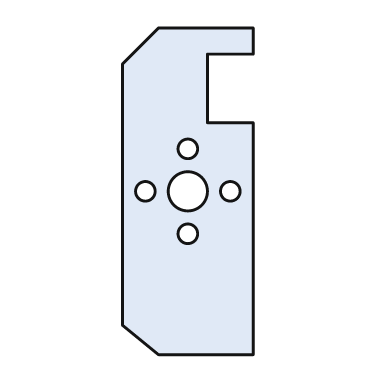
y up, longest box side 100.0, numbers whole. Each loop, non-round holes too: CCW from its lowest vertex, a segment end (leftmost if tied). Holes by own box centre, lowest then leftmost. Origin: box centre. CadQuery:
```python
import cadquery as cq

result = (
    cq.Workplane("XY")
    .moveTo(-9.0, -50.0)
    .lineTo(20.0, -50.0)
    .lineTo(20.0, 21.0)
    .lineTo(6.0, 21.0)
    .lineTo(6.0, 42.0)
    .lineTo(20.0, 42.0)
    .lineTo(20.0, 50.0)
    .lineTo(-9.0, 50.0)
    .lineTo(-20.0, 39.0)
    .lineTo(-20.0, -41.0)
    .close()
    .moveTo(0.0, -13.0)
    .circle(3.0)
    .moveTo(-13.0, 0.0)
    .circle(3.0)
    .moveTo(0.0, 0.0)
    .circle(6.0)
    .moveTo(13.0, 0.0)
    .circle(3.0)
    .moveTo(0.0, 13.0)
    .circle(3.0)
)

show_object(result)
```